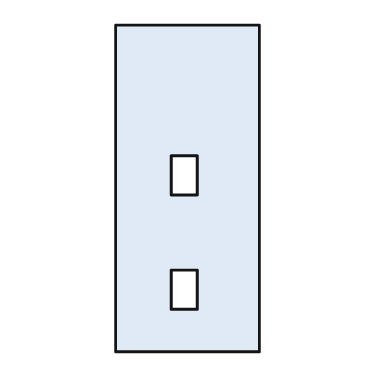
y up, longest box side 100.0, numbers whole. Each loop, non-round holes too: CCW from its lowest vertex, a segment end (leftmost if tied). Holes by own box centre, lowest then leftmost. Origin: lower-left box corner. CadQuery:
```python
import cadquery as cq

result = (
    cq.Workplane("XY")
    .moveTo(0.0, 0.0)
    .lineTo(44.0, 0.0)
    .lineTo(44.0, 100.0)
    .lineTo(0.0, 100.0)
    .close()
    .moveTo(17.0, 13.0)
    .lineTo(25.0, 13.0)
    .lineTo(25.0, 25.0)
    .lineTo(17.0, 25.0)
    .close()
    .moveTo(17.0, 48.0)
    .lineTo(25.0, 48.0)
    .lineTo(25.0, 60.0)
    .lineTo(17.0, 60.0)
    .close()
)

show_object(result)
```